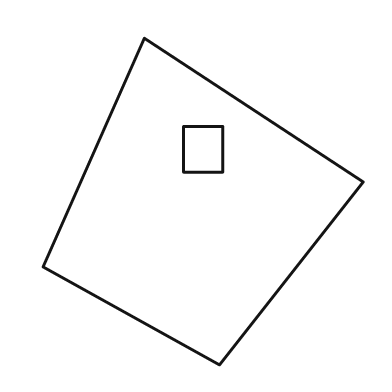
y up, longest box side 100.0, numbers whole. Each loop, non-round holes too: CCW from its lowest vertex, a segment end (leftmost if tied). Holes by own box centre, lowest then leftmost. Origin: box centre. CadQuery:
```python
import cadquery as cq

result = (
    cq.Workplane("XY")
    .moveTo(5.0, -50.0)
    .lineTo(49.0, 6.0)
    .lineTo(-18.0, 50.0)
    .lineTo(-49.0, -20.0)
    .close()
    .moveTo(-6.0, 9.0)
    .lineTo(6.0, 9.0)
    .lineTo(6.0, 23.0)
    .lineTo(-6.0, 23.0)
    .close()
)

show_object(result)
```